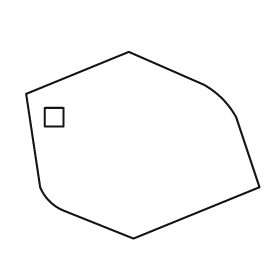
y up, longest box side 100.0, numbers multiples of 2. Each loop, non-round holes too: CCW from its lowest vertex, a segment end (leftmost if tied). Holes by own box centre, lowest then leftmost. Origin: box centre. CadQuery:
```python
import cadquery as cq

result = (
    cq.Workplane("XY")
    .moveTo(-4.0, -40.0)
    .lineTo(50.0, -18.0)
    .lineTo(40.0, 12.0)
    .threePointArc((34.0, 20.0), (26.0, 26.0))
    .lineTo(-6.0, 40.0)
    .lineTo(-50.0, 22.0)
    .lineTo(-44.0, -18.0)
    .threePointArc((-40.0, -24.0), (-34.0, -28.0))
    .close()
    .moveTo(-42.0, 8.0)
    .lineTo(-34.0, 8.0)
    .lineTo(-34.0, 16.0)
    .lineTo(-42.0, 16.0)
    .close()
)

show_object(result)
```